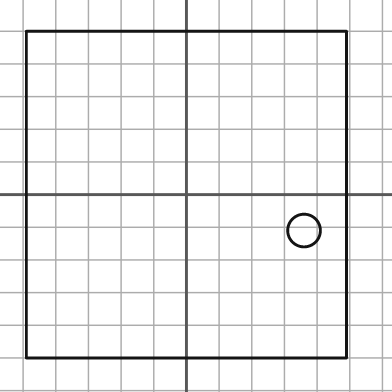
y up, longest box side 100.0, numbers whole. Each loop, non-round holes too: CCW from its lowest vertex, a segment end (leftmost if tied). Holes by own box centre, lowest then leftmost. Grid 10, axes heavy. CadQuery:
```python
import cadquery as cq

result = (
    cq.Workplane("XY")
    .moveTo(-49.0, -50.0)
    .lineTo(49.0, -50.0)
    .lineTo(49.0, 50.0)
    .lineTo(-49.0, 50.0)
    .close()
    .moveTo(36.0, -11.0)
    .circle(5.0)
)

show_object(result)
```